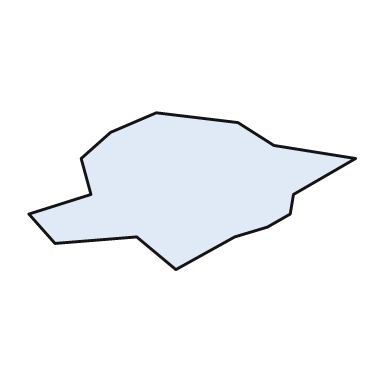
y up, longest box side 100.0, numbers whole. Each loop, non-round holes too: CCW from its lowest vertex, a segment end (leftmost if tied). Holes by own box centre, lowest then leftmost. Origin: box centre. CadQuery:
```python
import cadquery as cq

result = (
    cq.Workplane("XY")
    .moveTo(-5.0, -24.0)
    .lineTo(13.0, -14.0)
    .lineTo(23.0, -11.0)
    .lineTo(30.0, -7.0)
    .lineTo(31.0, -1.0)
    .lineTo(50.0, 10.0)
    .lineTo(25.0, 14.0)
    .lineTo(14.0, 21.0)
    .lineTo(-11.0, 24.0)
    .lineTo(-25.0, 18.0)
    .lineTo(-34.0, 10.0)
    .lineTo(-31.0, -1.0)
    .lineTo(-50.0, -7.0)
    .lineTo(-42.0, -16.0)
    .lineTo(-17.0, -14.0)
    .close()
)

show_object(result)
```